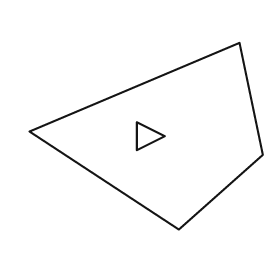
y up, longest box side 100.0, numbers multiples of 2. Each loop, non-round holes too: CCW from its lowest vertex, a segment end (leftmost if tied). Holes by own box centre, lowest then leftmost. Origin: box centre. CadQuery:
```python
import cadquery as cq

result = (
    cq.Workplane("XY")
    .moveTo(14.0, -40.0)
    .lineTo(50.0, -8.0)
    .lineTo(40.0, 40.0)
    .lineTo(-50.0, 2.0)
    .close()
    .moveTo(-4.0, -6.0)
    .lineTo(8.0, 0.0)
    .lineTo(-4.0, 6.0)
    .close()
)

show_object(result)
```